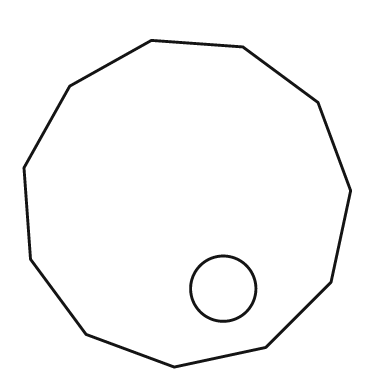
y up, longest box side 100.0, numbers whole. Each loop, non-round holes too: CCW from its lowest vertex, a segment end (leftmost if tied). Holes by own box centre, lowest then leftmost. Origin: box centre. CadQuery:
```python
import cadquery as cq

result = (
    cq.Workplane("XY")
    .moveTo(-4.0, -50.0)
    .lineTo(24.0, -44.0)
    .lineTo(44.0, -24.0)
    .lineTo(50.0, 4.0)
    .lineTo(40.0, 31.0)
    .lineTo(17.0, 48.0)
    .lineTo(-11.0, 50.0)
    .lineTo(-36.0, 36.0)
    .lineTo(-50.0, 11.0)
    .lineTo(-48.0, -17.0)
    .lineTo(-31.0, -40.0)
    .close()
    .moveTo(11.0, -26.0)
    .circle(10.0)
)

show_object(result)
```